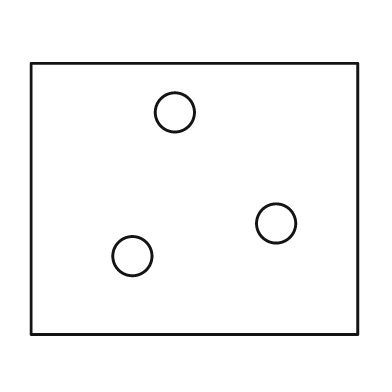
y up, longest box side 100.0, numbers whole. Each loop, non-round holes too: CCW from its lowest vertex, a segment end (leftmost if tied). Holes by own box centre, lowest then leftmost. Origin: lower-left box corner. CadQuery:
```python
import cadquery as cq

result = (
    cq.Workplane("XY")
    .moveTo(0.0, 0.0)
    .lineTo(100.0, 0.0)
    .lineTo(100.0, 83.0)
    .lineTo(0.0, 83.0)
    .close()
    .moveTo(31.0, 24.0)
    .circle(6.0)
    .moveTo(75.0, 34.0)
    .circle(6.0)
    .moveTo(44.0, 68.0)
    .circle(6.0)
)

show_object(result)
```